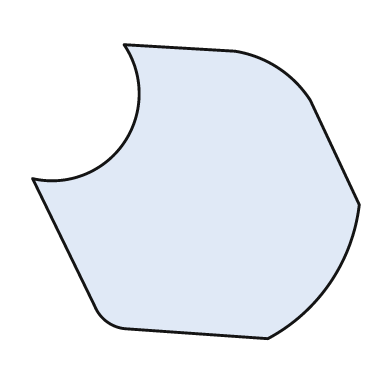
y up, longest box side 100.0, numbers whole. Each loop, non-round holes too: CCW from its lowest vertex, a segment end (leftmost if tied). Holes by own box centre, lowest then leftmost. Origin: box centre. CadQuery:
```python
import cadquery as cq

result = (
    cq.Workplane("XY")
    .moveTo(22.0, -45.0)
    .threePointArc((41.0, -28.0), (50.0, -4.0))
    .lineTo(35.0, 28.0)
    .threePointArc((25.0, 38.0), (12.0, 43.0))
    .lineTo(-22.0, 45.0)
    .threePointArc((-22.0, 15.0), (-50.0, 4.0))
    .lineTo(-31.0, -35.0)
    .threePointArc((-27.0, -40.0), (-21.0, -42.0))
    .close()
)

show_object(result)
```